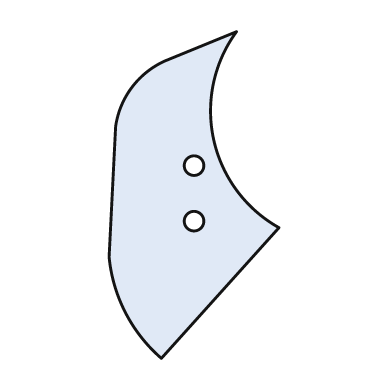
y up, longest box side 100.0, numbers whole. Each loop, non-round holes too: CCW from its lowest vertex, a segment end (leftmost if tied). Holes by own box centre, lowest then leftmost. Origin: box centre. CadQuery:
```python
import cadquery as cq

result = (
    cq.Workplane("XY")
    .moveTo(-10.0, -50.0)
    .lineTo(26.0, -10.0)
    .threePointArc((6.0, 17.0), (13.0, 50.0))
    .lineTo(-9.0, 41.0)
    .threePointArc((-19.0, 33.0), (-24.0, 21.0))
    .lineTo(-26.0, -19.0)
    .threePointArc((-21.0, -36.0), (-10.0, -50.0))
    .close()
    .moveTo(0.0, -8.0)
    .circle(3.0)
    .moveTo(0.0, 9.0)
    .circle(3.0)
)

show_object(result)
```